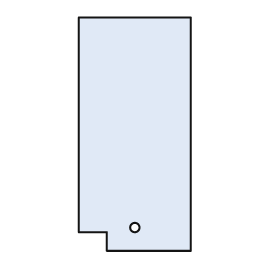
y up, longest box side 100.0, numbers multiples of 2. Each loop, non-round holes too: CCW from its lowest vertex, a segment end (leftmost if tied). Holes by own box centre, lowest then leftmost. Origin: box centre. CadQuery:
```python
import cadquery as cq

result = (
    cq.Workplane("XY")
    .moveTo(-12.0, -50.0)
    .lineTo(24.0, -50.0)
    .lineTo(24.0, 50.0)
    .lineTo(-24.0, 50.0)
    .lineTo(-24.0, -42.0)
    .lineTo(-12.0, -42.0)
    .close()
    .moveTo(0.0, -40.0)
    .circle(2.0)
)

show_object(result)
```